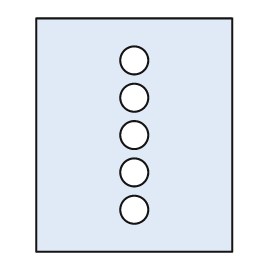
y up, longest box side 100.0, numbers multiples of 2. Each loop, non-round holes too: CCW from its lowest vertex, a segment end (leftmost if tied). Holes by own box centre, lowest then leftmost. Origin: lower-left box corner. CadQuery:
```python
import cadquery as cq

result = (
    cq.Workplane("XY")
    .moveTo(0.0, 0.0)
    .lineTo(84.0, 0.0)
    .lineTo(84.0, 100.0)
    .lineTo(0.0, 100.0)
    .close()
    .moveTo(42.0, 18.0)
    .circle(6.0)
    .moveTo(42.0, 34.0)
    .circle(6.0)
    .moveTo(42.0, 50.0)
    .circle(6.0)
    .moveTo(42.0, 66.0)
    .circle(6.0)
    .moveTo(42.0, 82.0)
    .circle(6.0)
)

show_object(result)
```